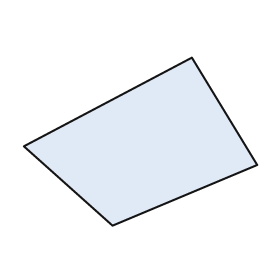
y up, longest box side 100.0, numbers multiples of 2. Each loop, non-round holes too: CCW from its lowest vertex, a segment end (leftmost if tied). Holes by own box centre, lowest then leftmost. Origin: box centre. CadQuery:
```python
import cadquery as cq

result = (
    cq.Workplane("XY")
    .moveTo(-12.0, -36.0)
    .lineTo(50.0, -10.0)
    .lineTo(22.0, 36.0)
    .lineTo(-50.0, -2.0)
    .close()
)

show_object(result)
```